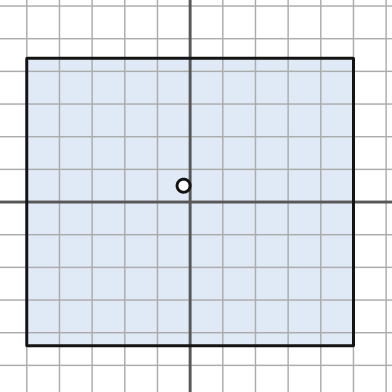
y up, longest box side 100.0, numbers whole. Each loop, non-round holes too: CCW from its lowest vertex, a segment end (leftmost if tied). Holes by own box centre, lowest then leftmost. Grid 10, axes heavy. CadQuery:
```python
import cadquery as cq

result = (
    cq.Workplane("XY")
    .moveTo(-50.0, -44.0)
    .lineTo(50.0, -44.0)
    .lineTo(50.0, 44.0)
    .lineTo(-50.0, 44.0)
    .close()
    .moveTo(-2.0, 5.0)
    .circle(2.0)
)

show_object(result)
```